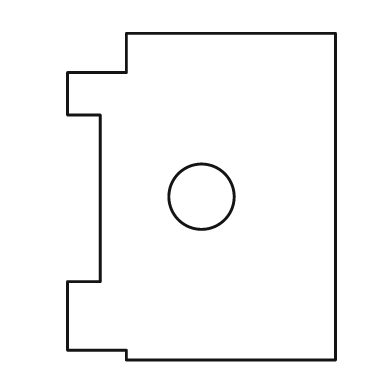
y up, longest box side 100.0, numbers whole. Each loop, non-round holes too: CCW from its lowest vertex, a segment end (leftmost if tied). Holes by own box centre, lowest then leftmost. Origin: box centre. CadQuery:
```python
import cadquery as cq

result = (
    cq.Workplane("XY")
    .moveTo(-23.0, -50.0)
    .lineTo(41.0, -50.0)
    .lineTo(41.0, 50.0)
    .lineTo(-23.0, 50.0)
    .lineTo(-23.0, 38.0)
    .lineTo(-41.0, 38.0)
    .lineTo(-41.0, 25.0)
    .lineTo(-31.0, 25.0)
    .lineTo(-31.0, -26.0)
    .lineTo(-41.0, -26.0)
    .lineTo(-41.0, -47.0)
    .lineTo(-23.0, -47.0)
    .close()
    .moveTo(0.0, 0.0)
    .circle(10.0)
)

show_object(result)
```